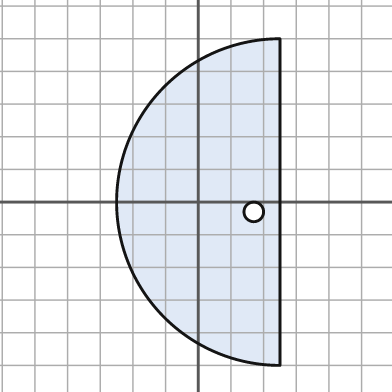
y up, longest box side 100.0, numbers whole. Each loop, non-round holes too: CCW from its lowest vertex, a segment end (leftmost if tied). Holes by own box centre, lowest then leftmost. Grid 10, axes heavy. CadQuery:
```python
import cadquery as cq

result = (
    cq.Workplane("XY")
    .moveTo(25.0, -50.0)
    .lineTo(25.0, 50.0)
    .threePointArc((-25.0, 0.0), (25.0, -50.0))
    .close()
    .moveTo(17.0, -3.0)
    .circle(3.0)
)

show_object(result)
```